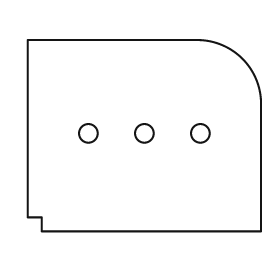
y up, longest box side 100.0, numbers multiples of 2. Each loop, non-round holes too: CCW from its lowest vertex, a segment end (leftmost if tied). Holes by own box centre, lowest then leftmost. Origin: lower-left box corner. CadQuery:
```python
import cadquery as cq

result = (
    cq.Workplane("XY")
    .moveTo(6.0, 0.0)
    .lineTo(100.0, 0.0)
    .lineTo(100.0, 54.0)
    .threePointArc((92.0, 74.0), (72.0, 82.0))
    .lineTo(0.0, 82.0)
    .lineTo(0.0, 6.0)
    .lineTo(6.0, 6.0)
    .close()
    .moveTo(26.0, 42.0)
    .circle(4.0)
    .moveTo(50.0, 42.0)
    .circle(4.0)
    .moveTo(74.0, 42.0)
    .circle(4.0)
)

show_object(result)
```